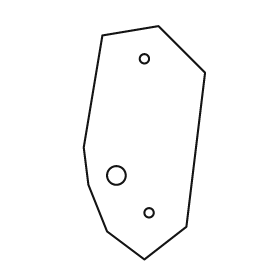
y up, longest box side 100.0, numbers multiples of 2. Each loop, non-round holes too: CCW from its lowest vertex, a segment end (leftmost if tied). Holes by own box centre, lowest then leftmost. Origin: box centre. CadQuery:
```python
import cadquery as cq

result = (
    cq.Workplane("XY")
    .moveTo(0.0, -50.0)
    .lineTo(18.0, -36.0)
    .lineTo(26.0, 30.0)
    .lineTo(6.0, 50.0)
    .lineTo(-18.0, 46.0)
    .lineTo(-26.0, -2.0)
    .lineTo(-24.0, -18.0)
    .lineTo(-16.0, -38.0)
    .close()
    .moveTo(2.0, -30.0)
    .circle(2.0)
    .moveTo(-12.0, -14.0)
    .circle(4.0)
    .moveTo(0.0, 36.0)
    .circle(2.0)
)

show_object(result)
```